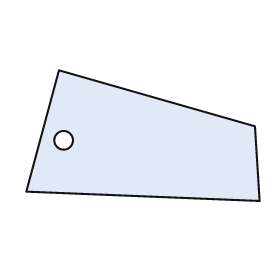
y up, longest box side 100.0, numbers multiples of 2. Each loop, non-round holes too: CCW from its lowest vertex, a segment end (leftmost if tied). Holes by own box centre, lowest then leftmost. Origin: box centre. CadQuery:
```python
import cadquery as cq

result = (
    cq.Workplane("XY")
    .moveTo(50.0, -28.0)
    .lineTo(48.0, 4.0)
    .lineTo(-36.0, 28.0)
    .lineTo(-50.0, -24.0)
    .close()
    .moveTo(-34.0, -2.0)
    .circle(4.0)
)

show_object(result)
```